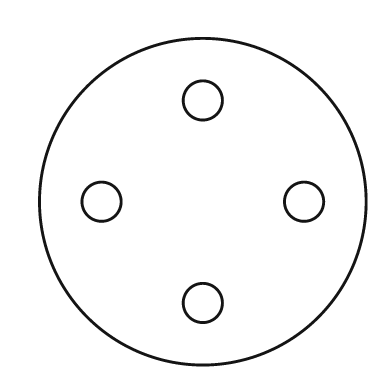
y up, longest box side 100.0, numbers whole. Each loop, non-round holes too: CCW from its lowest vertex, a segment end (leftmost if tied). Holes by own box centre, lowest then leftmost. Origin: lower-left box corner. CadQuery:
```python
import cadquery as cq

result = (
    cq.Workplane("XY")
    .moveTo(50.0, 50.0)
    .circle(50.0)
    .moveTo(50.0, 19.0)
    .circle(6.0)
    .moveTo(19.0, 50.0)
    .circle(6.0)
    .moveTo(81.0, 50.0)
    .circle(6.0)
    .moveTo(50.0, 81.0)
    .circle(6.0)
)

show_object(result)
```